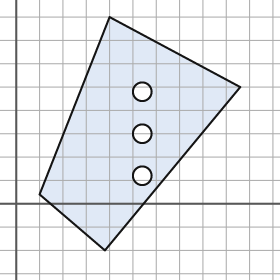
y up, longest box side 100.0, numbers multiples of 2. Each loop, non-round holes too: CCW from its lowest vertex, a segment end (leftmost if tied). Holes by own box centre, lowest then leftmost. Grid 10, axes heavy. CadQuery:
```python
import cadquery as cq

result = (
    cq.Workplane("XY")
    .moveTo(38.0, -20.0)
    .lineTo(96.0, 50.0)
    .lineTo(40.0, 80.0)
    .lineTo(10.0, 4.0)
    .close()
    .moveTo(54.0, 12.0)
    .circle(4.0)
    .moveTo(54.0, 30.0)
    .circle(4.0)
    .moveTo(54.0, 48.0)
    .circle(4.0)
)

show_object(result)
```